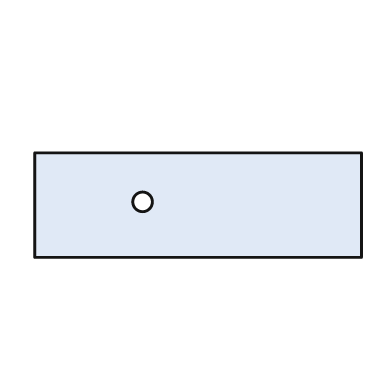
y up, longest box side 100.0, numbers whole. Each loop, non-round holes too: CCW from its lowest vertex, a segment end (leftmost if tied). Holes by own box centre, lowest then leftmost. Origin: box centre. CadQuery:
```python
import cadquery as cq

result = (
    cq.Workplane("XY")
    .moveTo(-50.0, -16.0)
    .lineTo(50.0, -16.0)
    .lineTo(50.0, 16.0)
    .lineTo(-50.0, 16.0)
    .close()
    .moveTo(-17.0, 1.0)
    .circle(3.0)
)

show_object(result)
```